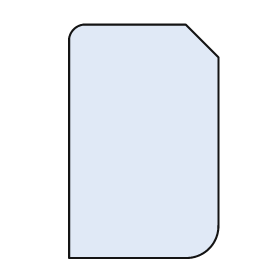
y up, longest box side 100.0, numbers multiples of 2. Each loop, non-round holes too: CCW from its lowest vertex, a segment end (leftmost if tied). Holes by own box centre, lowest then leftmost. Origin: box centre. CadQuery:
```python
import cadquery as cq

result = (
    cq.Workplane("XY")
    .moveTo(-32.0, -50.0)
    .lineTo(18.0, -50.0)
    .threePointArc((28.0, -46.0), (32.0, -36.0))
    .lineTo(32.0, 36.0)
    .lineTo(18.0, 50.0)
    .lineTo(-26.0, 50.0)
    .threePointArc((-30.0, 48.0), (-32.0, 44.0))
    .close()
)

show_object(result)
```